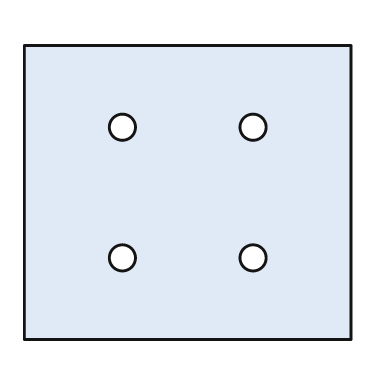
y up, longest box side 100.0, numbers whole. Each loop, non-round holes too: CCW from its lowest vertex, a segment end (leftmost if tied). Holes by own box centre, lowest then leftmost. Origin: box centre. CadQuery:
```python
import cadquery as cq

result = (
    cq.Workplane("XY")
    .moveTo(-50.0, -45.0)
    .lineTo(50.0, -45.0)
    .lineTo(50.0, 45.0)
    .lineTo(-50.0, 45.0)
    .close()
    .moveTo(-20.0, -20.0)
    .circle(4.0)
    .moveTo(20.0, -20.0)
    .circle(4.0)
    .moveTo(-20.0, 20.0)
    .circle(4.0)
    .moveTo(20.0, 20.0)
    .circle(4.0)
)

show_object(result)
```